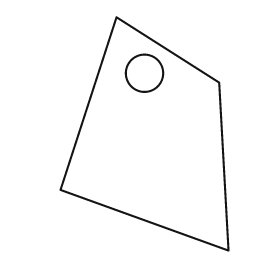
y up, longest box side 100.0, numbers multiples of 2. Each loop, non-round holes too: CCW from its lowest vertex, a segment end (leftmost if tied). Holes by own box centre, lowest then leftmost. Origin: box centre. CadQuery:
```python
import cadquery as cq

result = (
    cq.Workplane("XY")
    .moveTo(36.0, -50.0)
    .lineTo(32.0, 22.0)
    .lineTo(-12.0, 50.0)
    .lineTo(-36.0, -24.0)
    .close()
    .moveTo(0.0, 26.0)
    .circle(8.0)
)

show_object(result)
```